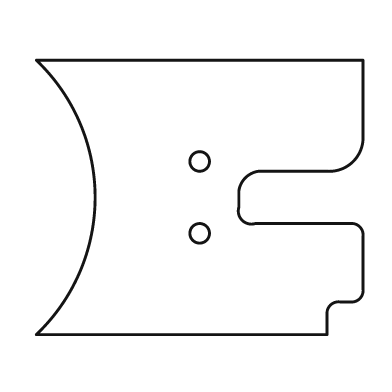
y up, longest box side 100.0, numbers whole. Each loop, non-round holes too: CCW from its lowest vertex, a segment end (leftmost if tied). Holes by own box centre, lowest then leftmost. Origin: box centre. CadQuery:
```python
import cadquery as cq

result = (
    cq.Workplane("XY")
    .moveTo(-50.0, -42.0)
    .lineTo(39.0, -42.0)
    .lineTo(39.0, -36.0)
    .threePointArc((40.0, -33.0), (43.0, -32.0))
    .lineTo(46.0, -32.0)
    .threePointArc((49.0, -31.0), (50.0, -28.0))
    .lineTo(50.0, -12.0)
    .threePointArc((49.0, -9.0), (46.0, -8.0))
    .lineTo(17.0, -8.0)
    .threePointArc((13.0, -7.0), (12.0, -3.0))
    .lineTo(12.0, 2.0)
    .threePointArc((14.0, 6.0), (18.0, 8.0))
    .lineTo(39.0, 8.0)
    .threePointArc((47.0, 11.0), (50.0, 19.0))
    .lineTo(50.0, 42.0)
    .lineTo(-50.0, 42.0)
    .threePointArc((-32.0, 0.0), (-50.0, -42.0))
    .close()
    .moveTo(0.0, -11.0)
    .circle(3.0)
    .moveTo(0.0, 11.0)
    .circle(3.0)
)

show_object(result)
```